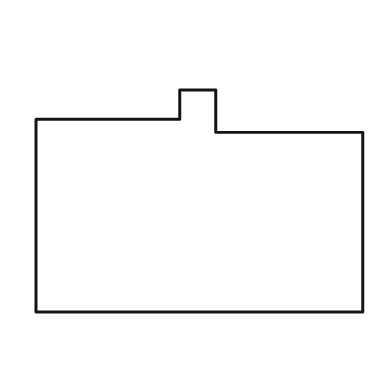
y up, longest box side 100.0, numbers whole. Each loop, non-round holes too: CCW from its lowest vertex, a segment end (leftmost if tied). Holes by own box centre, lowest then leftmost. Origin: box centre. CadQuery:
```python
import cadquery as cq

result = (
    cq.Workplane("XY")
    .moveTo(-50.0, -34.0)
    .lineTo(50.0, -34.0)
    .lineTo(50.0, 21.0)
    .lineTo(5.0, 21.0)
    .lineTo(5.0, 34.0)
    .lineTo(-6.0, 34.0)
    .lineTo(-6.0, 25.0)
    .lineTo(-50.0, 25.0)
    .close()
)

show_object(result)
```